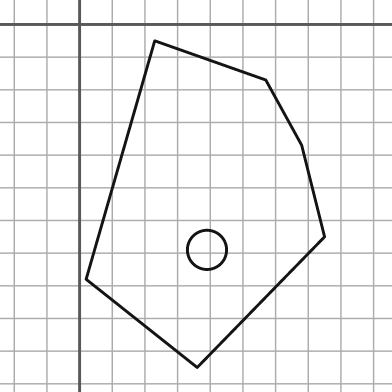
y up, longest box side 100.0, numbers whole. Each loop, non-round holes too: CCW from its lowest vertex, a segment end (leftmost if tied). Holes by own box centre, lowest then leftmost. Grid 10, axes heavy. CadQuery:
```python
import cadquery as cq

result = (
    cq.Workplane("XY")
    .moveTo(36.0, -105.0)
    .lineTo(75.0, -65.0)
    .lineTo(68.0, -37.0)
    .lineTo(57.0, -17.0)
    .lineTo(23.0, -5.0)
    .lineTo(2.0, -78.0)
    .close()
    .moveTo(39.0, -69.0)
    .circle(6.0)
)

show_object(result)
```